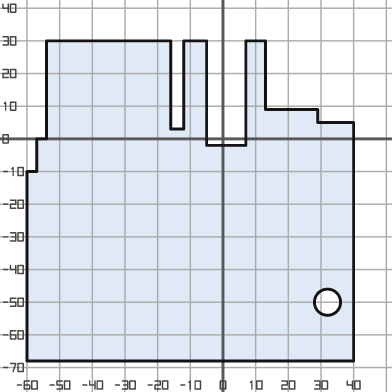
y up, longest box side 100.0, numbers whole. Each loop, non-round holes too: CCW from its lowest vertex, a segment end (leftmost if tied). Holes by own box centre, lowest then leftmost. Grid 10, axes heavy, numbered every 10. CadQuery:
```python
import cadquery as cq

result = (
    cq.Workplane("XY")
    .moveTo(-60.0, -68.0)
    .lineTo(40.0, -68.0)
    .lineTo(40.0, 5.0)
    .lineTo(29.0, 5.0)
    .lineTo(29.0, 9.0)
    .lineTo(13.0, 9.0)
    .lineTo(13.0, 30.0)
    .lineTo(7.0, 30.0)
    .lineTo(7.0, -2.0)
    .lineTo(-5.0, -2.0)
    .lineTo(-5.0, 30.0)
    .lineTo(-12.0, 30.0)
    .lineTo(-12.0, 3.0)
    .lineTo(-16.0, 3.0)
    .lineTo(-16.0, 30.0)
    .lineTo(-54.0, 30.0)
    .lineTo(-54.0, 0.0)
    .lineTo(-57.0, 0.0)
    .lineTo(-57.0, -10.0)
    .lineTo(-60.0, -10.0)
    .close()
    .moveTo(32.0, -50.0)
    .circle(4.0)
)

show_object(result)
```